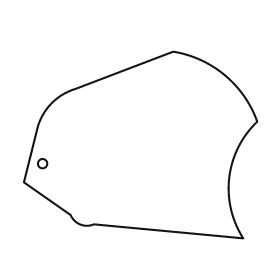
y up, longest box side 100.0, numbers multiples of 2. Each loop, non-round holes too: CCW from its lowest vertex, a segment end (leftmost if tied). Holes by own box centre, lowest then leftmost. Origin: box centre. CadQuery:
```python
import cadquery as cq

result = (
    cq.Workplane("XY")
    .moveTo(44.0, -40.0)
    .threePointArc((38.0, -14.0), (50.0, 10.0))
    .threePointArc((36.0, 30.0), (14.0, 40.0))
    .lineTo(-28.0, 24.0)
    .threePointArc((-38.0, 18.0), (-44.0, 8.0))
    .lineTo(-50.0, -16.0)
    .lineTo(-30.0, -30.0)
    .threePointArc((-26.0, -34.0), (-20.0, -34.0))
    .close()
    .moveTo(-42.0, -8.0)
    .circle(2.0)
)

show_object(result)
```